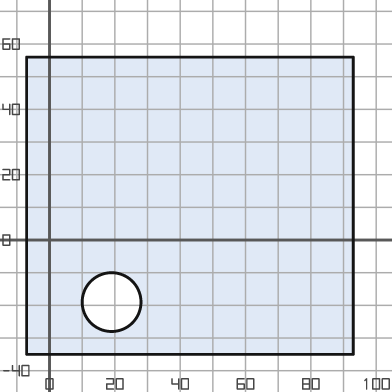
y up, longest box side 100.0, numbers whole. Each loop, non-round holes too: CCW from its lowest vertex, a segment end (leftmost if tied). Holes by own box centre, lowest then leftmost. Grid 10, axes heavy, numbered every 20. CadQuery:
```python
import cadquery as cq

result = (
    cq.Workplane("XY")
    .moveTo(-7.0, -35.0)
    .lineTo(93.0, -35.0)
    .lineTo(93.0, 56.0)
    .lineTo(-7.0, 56.0)
    .close()
    .moveTo(19.0, -19.0)
    .circle(9.0)
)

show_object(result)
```